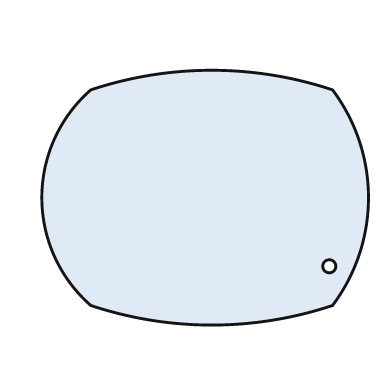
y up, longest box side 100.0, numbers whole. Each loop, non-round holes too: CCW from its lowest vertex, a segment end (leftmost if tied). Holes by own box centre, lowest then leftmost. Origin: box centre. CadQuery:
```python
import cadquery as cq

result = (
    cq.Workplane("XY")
    .moveTo(-35.0, -33.0)
    .threePointArc((2.0, -39.0), (39.0, -33.0))
    .threePointArc((50.0, 0.0), (39.0, 33.0))
    .threePointArc((2.0, 39.0), (-35.0, 33.0))
    .threePointArc((-50.0, 0.0), (-35.0, -33.0))
    .close()
    .moveTo(38.0, -21.0)
    .circle(2.0)
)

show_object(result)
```